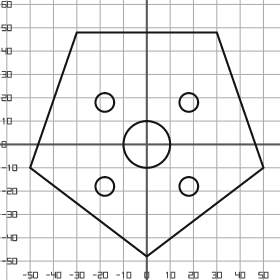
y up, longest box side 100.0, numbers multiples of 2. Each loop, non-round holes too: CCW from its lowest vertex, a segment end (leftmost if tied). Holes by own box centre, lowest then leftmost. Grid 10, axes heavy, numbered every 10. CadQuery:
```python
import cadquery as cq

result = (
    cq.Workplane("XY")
    .moveTo(0.0, -48.0)
    .lineTo(50.0, -10.0)
    .lineTo(30.0, 48.0)
    .lineTo(-30.0, 48.0)
    .lineTo(-50.0, -10.0)
    .close()
    .moveTo(-18.0, -18.0)
    .circle(4.0)
    .moveTo(18.0, -18.0)
    .circle(4.0)
    .moveTo(0.0, 0.0)
    .circle(10.0)
    .moveTo(-18.0, 18.0)
    .circle(4.0)
    .moveTo(18.0, 18.0)
    .circle(4.0)
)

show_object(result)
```